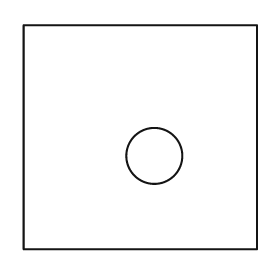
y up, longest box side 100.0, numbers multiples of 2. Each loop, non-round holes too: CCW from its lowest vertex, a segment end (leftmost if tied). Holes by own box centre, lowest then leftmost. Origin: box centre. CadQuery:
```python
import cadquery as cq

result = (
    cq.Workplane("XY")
    .moveTo(-50.0, -48.0)
    .lineTo(50.0, -48.0)
    .lineTo(50.0, 48.0)
    .lineTo(-50.0, 48.0)
    .close()
    .moveTo(6.0, -8.0)
    .circle(12.0)
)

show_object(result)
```